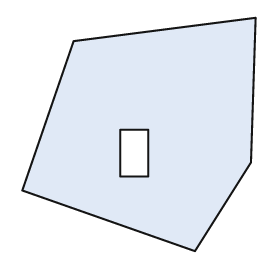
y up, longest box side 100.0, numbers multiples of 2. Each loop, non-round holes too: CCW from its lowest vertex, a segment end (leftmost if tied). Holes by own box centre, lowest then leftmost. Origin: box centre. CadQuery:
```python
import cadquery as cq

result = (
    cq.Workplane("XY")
    .moveTo(24.0, -50.0)
    .lineTo(48.0, -12.0)
    .lineTo(50.0, 50.0)
    .lineTo(-28.0, 40.0)
    .lineTo(-50.0, -24.0)
    .close()
    .moveTo(-8.0, -18.0)
    .lineTo(4.0, -18.0)
    .lineTo(4.0, 2.0)
    .lineTo(-8.0, 2.0)
    .close()
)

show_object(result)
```